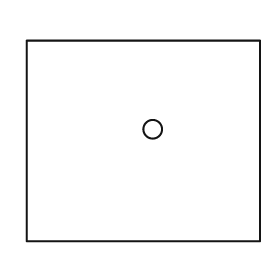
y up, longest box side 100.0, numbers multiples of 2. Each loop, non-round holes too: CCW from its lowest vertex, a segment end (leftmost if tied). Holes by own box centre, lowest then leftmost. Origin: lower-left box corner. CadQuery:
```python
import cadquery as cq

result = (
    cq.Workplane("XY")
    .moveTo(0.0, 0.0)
    .lineTo(100.0, 0.0)
    .lineTo(100.0, 86.0)
    .lineTo(0.0, 86.0)
    .close()
    .moveTo(54.0, 48.0)
    .circle(4.0)
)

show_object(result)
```